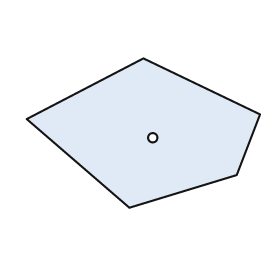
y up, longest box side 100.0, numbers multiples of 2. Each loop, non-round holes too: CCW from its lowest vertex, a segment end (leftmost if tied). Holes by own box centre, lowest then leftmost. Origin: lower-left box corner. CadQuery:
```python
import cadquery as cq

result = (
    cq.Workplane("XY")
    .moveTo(44.0, 0.0)
    .lineTo(90.0, 14.0)
    .lineTo(100.0, 40.0)
    .lineTo(50.0, 64.0)
    .lineTo(0.0, 38.0)
    .close()
    .moveTo(54.0, 30.0)
    .circle(2.0)
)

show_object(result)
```